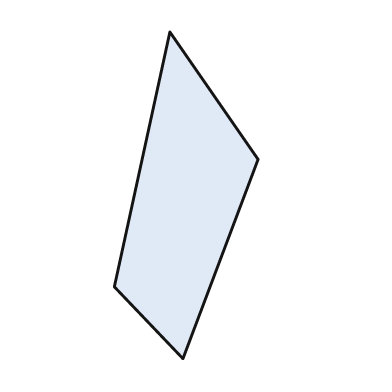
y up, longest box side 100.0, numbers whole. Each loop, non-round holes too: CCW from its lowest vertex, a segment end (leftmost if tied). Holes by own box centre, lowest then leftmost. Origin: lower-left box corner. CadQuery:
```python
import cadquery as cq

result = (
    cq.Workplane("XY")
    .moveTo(21.0, 0.0)
    .lineTo(44.0, 61.0)
    .lineTo(17.0, 100.0)
    .lineTo(0.0, 22.0)
    .close()
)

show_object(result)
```